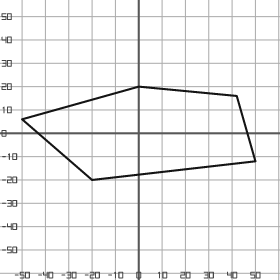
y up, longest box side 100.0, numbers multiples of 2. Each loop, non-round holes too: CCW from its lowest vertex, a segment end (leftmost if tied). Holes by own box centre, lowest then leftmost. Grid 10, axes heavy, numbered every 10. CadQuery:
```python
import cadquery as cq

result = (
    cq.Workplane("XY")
    .moveTo(-20.0, -20.0)
    .lineTo(50.0, -12.0)
    .lineTo(42.0, 16.0)
    .lineTo(0.0, 20.0)
    .lineTo(-50.0, 6.0)
    .close()
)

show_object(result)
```